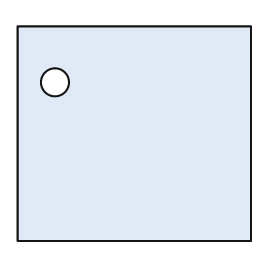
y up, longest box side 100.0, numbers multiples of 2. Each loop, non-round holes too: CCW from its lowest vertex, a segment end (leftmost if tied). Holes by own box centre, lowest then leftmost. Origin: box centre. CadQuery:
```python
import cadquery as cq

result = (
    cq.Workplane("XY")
    .moveTo(-50.0, -46.0)
    .lineTo(50.0, -46.0)
    .lineTo(50.0, 46.0)
    .lineTo(-50.0, 46.0)
    .close()
    .moveTo(-34.0, 22.0)
    .circle(6.0)
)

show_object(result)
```